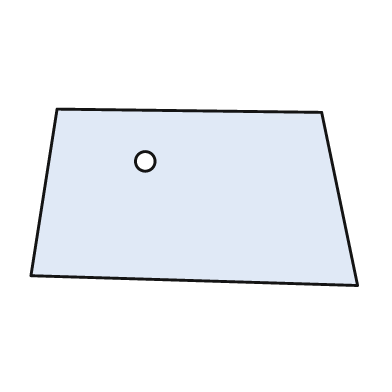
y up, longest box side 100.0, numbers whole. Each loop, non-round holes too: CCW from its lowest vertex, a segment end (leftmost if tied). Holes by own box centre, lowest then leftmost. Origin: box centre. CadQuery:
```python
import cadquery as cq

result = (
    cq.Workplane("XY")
    .moveTo(50.0, -27.0)
    .lineTo(39.0, 26.0)
    .lineTo(-42.0, 27.0)
    .lineTo(-50.0, -24.0)
    .close()
    .moveTo(-15.0, 11.0)
    .circle(3.0)
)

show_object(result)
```